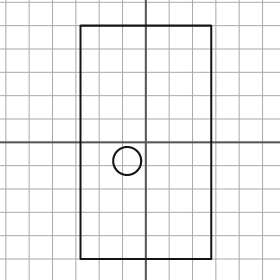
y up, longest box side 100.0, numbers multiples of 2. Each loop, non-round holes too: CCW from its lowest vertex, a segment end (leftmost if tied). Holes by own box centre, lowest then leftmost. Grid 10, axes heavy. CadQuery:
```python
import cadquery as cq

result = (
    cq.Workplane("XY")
    .moveTo(-28.0, -50.0)
    .lineTo(28.0, -50.0)
    .lineTo(28.0, 50.0)
    .lineTo(-28.0, 50.0)
    .close()
    .moveTo(-8.0, -8.0)
    .circle(6.0)
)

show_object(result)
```